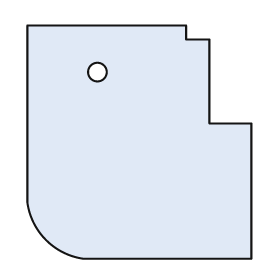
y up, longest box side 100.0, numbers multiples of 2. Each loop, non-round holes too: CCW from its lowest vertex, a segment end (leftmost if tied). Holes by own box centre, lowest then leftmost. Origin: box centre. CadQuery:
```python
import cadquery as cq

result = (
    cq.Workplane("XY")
    .moveTo(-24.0, -50.0)
    .lineTo(48.0, -50.0)
    .lineTo(48.0, 8.0)
    .lineTo(30.0, 8.0)
    .lineTo(30.0, 44.0)
    .lineTo(20.0, 44.0)
    .lineTo(20.0, 50.0)
    .lineTo(-48.0, 50.0)
    .lineTo(-48.0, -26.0)
    .threePointArc((-40.0, -42.0), (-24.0, -50.0))
    .close()
    .moveTo(-18.0, 30.0)
    .circle(4.0)
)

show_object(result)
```